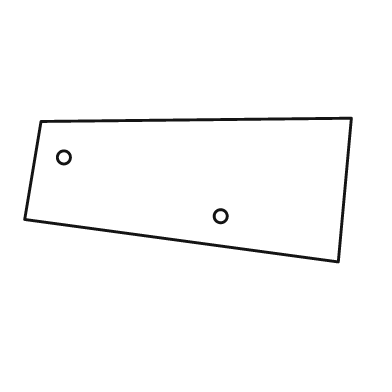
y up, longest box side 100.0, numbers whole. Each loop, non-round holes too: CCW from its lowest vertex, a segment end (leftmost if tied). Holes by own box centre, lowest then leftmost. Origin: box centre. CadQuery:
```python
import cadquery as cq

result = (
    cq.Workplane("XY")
    .moveTo(46.0, -22.0)
    .lineTo(50.0, 22.0)
    .lineTo(-45.0, 21.0)
    .lineTo(-50.0, -9.0)
    .close()
    .moveTo(10.0, -8.0)
    .circle(2.0)
    .moveTo(-38.0, 10.0)
    .circle(2.0)
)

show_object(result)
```